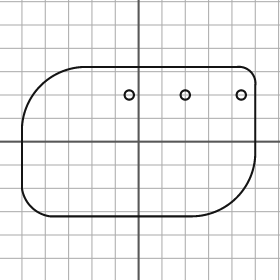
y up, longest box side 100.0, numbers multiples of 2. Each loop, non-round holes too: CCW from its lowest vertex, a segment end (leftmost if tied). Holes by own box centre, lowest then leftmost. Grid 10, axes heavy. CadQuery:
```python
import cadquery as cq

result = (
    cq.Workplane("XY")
    .moveTo(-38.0, -32.0)
    .lineTo(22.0, -32.0)
    .threePointArc((42.0, -24.0), (50.0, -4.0))
    .lineTo(50.0, 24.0)
    .threePointArc((48.0, 30.0), (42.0, 32.0))
    .lineTo(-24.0, 32.0)
    .threePointArc((-42.0, 24.0), (-50.0, 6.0))
    .lineTo(-50.0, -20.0)
    .threePointArc((-46.0, -28.0), (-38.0, -32.0))
    .close()
    .moveTo(-4.0, 20.0)
    .circle(2.0)
    .moveTo(20.0, 20.0)
    .circle(2.0)
    .moveTo(44.0, 20.0)
    .circle(2.0)
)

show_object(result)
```